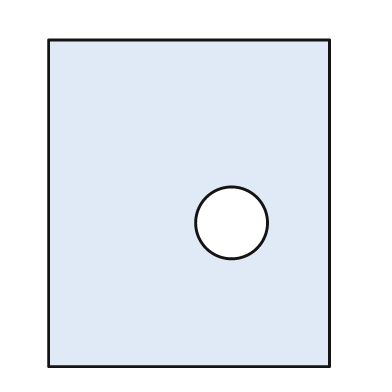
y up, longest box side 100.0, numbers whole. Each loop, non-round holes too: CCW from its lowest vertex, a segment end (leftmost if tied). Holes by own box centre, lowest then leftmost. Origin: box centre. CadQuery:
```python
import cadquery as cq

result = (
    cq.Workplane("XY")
    .moveTo(-43.0, -50.0)
    .lineTo(43.0, -50.0)
    .lineTo(43.0, 50.0)
    .lineTo(-43.0, 50.0)
    .close()
    .moveTo(13.0, -6.0)
    .circle(11.0)
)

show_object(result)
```